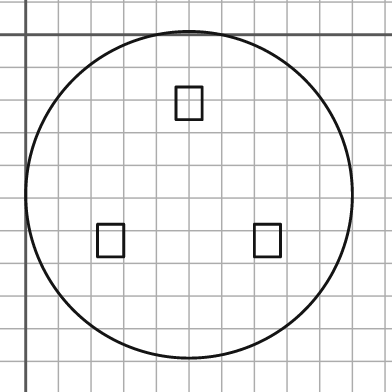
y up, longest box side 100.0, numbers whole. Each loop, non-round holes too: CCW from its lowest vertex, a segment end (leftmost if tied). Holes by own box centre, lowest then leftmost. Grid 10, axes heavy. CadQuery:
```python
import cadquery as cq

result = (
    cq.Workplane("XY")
    .moveTo(50.0, -49.0)
    .circle(50.0)
    .moveTo(22.0, -68.0)
    .lineTo(30.0, -68.0)
    .lineTo(30.0, -58.0)
    .lineTo(22.0, -58.0)
    .close()
    .moveTo(70.0, -68.0)
    .lineTo(78.0, -68.0)
    .lineTo(78.0, -58.0)
    .lineTo(70.0, -58.0)
    .close()
    .moveTo(46.0, -26.0)
    .lineTo(54.0, -26.0)
    .lineTo(54.0, -16.0)
    .lineTo(46.0, -16.0)
    .close()
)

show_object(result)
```